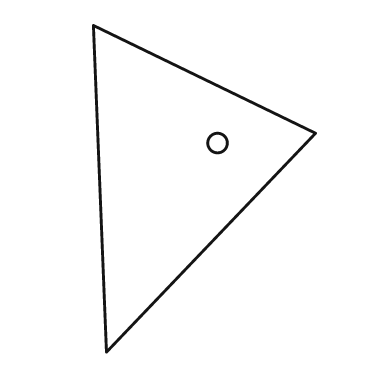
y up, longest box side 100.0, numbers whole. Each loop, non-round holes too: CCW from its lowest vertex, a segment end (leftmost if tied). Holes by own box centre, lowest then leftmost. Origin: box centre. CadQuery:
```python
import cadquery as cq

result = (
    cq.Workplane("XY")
    .moveTo(-30.0, -50.0)
    .lineTo(34.0, 17.0)
    .lineTo(-34.0, 50.0)
    .close()
    .moveTo(4.0, 14.0)
    .circle(3.0)
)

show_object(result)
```